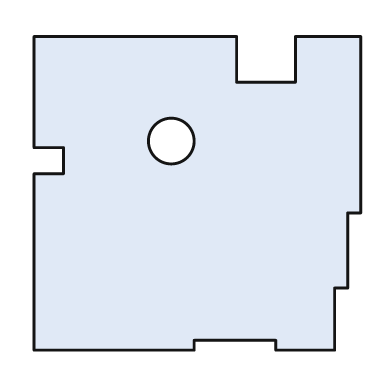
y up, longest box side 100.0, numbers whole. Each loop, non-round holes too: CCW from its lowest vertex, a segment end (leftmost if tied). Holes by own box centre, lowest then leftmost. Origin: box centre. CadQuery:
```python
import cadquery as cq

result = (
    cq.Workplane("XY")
    .moveTo(-50.0, -48.0)
    .lineTo(-1.0, -48.0)
    .lineTo(-1.0, -45.0)
    .lineTo(24.0, -45.0)
    .lineTo(24.0, -48.0)
    .lineTo(42.0, -48.0)
    .lineTo(42.0, -29.0)
    .lineTo(46.0, -29.0)
    .lineTo(46.0, -6.0)
    .lineTo(50.0, -6.0)
    .lineTo(50.0, 48.0)
    .lineTo(30.0, 48.0)
    .lineTo(30.0, 34.0)
    .lineTo(12.0, 34.0)
    .lineTo(12.0, 48.0)
    .lineTo(-50.0, 48.0)
    .lineTo(-50.0, 14.0)
    .lineTo(-41.0, 14.0)
    .lineTo(-41.0, 6.0)
    .lineTo(-50.0, 6.0)
    .close()
    .moveTo(-8.0, 16.0)
    .circle(7.0)
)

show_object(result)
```